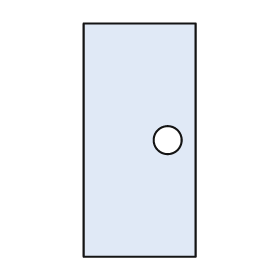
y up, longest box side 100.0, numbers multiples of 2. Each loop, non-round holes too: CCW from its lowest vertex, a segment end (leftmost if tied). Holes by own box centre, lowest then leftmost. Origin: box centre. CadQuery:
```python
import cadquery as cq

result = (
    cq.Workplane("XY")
    .moveTo(-24.0, -50.0)
    .lineTo(24.0, -50.0)
    .lineTo(24.0, 50.0)
    .lineTo(-24.0, 50.0)
    .close()
    .moveTo(12.0, 0.0)
    .circle(6.0)
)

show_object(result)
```